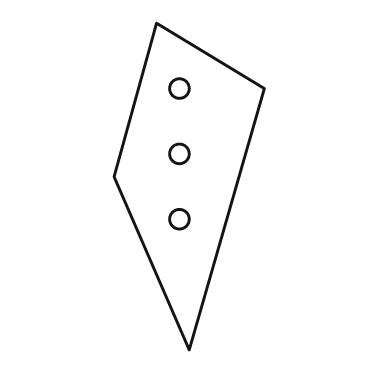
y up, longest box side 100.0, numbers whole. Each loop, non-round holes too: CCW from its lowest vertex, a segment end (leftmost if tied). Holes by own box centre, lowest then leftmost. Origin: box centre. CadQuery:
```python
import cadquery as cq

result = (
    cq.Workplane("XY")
    .moveTo(0.0, -50.0)
    .lineTo(23.0, 30.0)
    .lineTo(-10.0, 50.0)
    .lineTo(-23.0, 3.0)
    .close()
    .moveTo(-3.0, -10.0)
    .circle(3.0)
    .moveTo(-3.0, 10.0)
    .circle(3.0)
    .moveTo(-3.0, 30.0)
    .circle(3.0)
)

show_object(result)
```